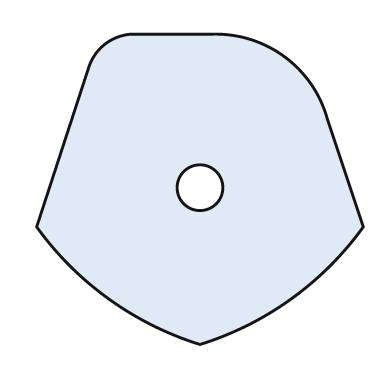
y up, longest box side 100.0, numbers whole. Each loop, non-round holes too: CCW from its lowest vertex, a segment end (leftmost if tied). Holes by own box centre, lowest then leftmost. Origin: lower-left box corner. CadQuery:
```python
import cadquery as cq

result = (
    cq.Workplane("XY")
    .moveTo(50.0, 0.0)
    .threePointArc((78.0, 14.0), (100.0, 36.0))
    .lineTo(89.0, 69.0)
    .threePointArc((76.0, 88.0), (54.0, 95.0))
    .lineTo(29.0, 95.0)
    .threePointArc((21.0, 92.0), (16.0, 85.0))
    .lineTo(0.0, 36.0)
    .threePointArc((22.0, 14.0), (50.0, 0.0))
    .close()
    .moveTo(50.0, 48.0)
    .circle(7.0)
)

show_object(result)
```